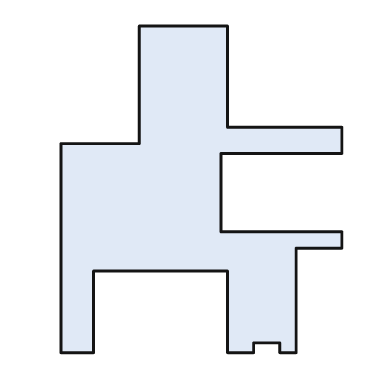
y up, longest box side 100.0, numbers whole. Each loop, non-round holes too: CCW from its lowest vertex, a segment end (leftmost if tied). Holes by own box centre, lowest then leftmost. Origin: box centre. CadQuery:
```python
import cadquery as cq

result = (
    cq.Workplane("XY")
    .moveTo(-43.0, -50.0)
    .lineTo(-33.0, -50.0)
    .lineTo(-33.0, -25.0)
    .lineTo(8.0, -25.0)
    .lineTo(8.0, -50.0)
    .lineTo(16.0, -50.0)
    .lineTo(16.0, -47.0)
    .lineTo(24.0, -47.0)
    .lineTo(24.0, -50.0)
    .lineTo(29.0, -50.0)
    .lineTo(29.0, -18.0)
    .lineTo(43.0, -18.0)
    .lineTo(43.0, -13.0)
    .lineTo(6.0, -13.0)
    .lineTo(6.0, 11.0)
    .lineTo(43.0, 11.0)
    .lineTo(43.0, 19.0)
    .lineTo(8.0, 19.0)
    .lineTo(8.0, 50.0)
    .lineTo(-19.0, 50.0)
    .lineTo(-19.0, 14.0)
    .lineTo(-43.0, 14.0)
    .close()
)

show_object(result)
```